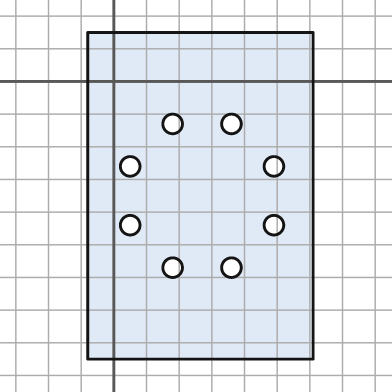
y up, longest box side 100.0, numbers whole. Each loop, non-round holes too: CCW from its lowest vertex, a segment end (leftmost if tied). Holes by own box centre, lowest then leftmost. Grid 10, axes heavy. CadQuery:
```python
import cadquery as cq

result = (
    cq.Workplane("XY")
    .moveTo(-8.0, -85.0)
    .lineTo(61.0, -85.0)
    .lineTo(61.0, 15.0)
    .lineTo(-8.0, 15.0)
    .close()
    .moveTo(18.0, -57.0)
    .circle(3.0)
    .moveTo(36.0, -57.0)
    .circle(3.0)
    .moveTo(5.0, -44.0)
    .circle(3.0)
    .moveTo(49.0, -44.0)
    .circle(3.0)
    .moveTo(5.0, -26.0)
    .circle(3.0)
    .moveTo(49.0, -26.0)
    .circle(3.0)
    .moveTo(18.0, -13.0)
    .circle(3.0)
    .moveTo(36.0, -13.0)
    .circle(3.0)
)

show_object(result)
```